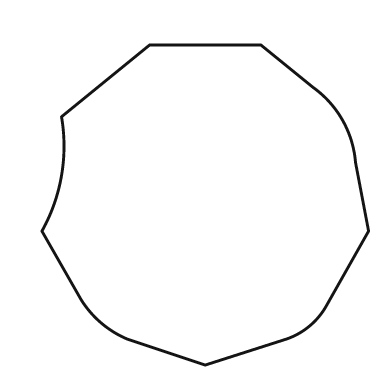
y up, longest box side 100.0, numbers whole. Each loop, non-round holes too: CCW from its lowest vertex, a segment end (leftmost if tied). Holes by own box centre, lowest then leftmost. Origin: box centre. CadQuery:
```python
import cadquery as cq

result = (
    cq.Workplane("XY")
    .moveTo(0.0, -49.0)
    .lineTo(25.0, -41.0)
    .threePointArc((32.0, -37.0), (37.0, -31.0))
    .lineTo(50.0, -8.0)
    .lineTo(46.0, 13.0)
    .threePointArc((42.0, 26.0), (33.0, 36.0))
    .lineTo(17.0, 49.0)
    .lineTo(-17.0, 49.0)
    .lineTo(-44.0, 27.0)
    .threePointArc((-44.0, 9.0), (-50.0, -8.0))
    .lineTo(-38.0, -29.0)
    .threePointArc((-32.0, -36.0), (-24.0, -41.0))
    .close()
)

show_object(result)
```